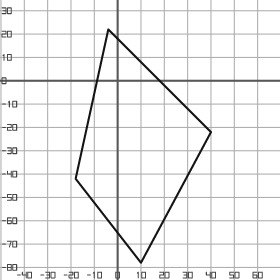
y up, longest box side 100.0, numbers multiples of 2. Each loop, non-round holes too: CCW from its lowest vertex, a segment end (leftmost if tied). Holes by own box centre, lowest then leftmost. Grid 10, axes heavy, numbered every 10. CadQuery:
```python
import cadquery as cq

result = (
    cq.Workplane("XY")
    .moveTo(10.0, -78.0)
    .lineTo(40.0, -22.0)
    .lineTo(-4.0, 22.0)
    .lineTo(-18.0, -42.0)
    .close()
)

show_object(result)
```